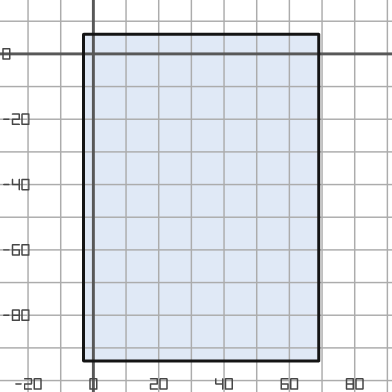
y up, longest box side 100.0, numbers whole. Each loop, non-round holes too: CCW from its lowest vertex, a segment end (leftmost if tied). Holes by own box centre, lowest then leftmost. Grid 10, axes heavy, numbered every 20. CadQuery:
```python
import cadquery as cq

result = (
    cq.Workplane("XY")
    .moveTo(-3.0, -94.0)
    .lineTo(69.0, -94.0)
    .lineTo(69.0, 6.0)
    .lineTo(-3.0, 6.0)
    .close()
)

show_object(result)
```